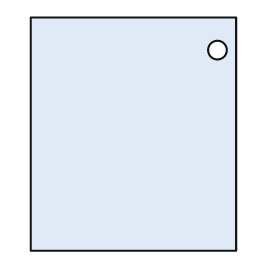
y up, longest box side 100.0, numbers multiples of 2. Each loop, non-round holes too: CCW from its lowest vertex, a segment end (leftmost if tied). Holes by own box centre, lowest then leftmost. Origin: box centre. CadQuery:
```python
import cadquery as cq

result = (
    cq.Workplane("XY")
    .moveTo(-44.0, -50.0)
    .lineTo(44.0, -50.0)
    .lineTo(44.0, 50.0)
    .lineTo(-44.0, 50.0)
    .close()
    .moveTo(36.0, 36.0)
    .circle(4.0)
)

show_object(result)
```